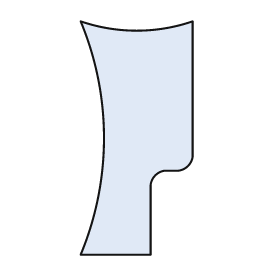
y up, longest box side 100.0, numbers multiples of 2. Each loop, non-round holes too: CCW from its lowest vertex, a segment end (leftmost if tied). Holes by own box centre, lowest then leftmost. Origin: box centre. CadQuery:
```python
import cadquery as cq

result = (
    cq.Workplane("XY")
    .moveTo(-24.0, -50.0)
    .lineTo(6.0, -50.0)
    .lineTo(6.0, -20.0)
    .threePointArc((8.0, -16.0), (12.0, -14.0))
    .lineTo(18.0, -14.0)
    .threePointArc((22.0, -12.0), (24.0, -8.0))
    .lineTo(24.0, 50.0)
    .threePointArc((0.0, 46.0), (-24.0, 50.0))
    .threePointArc((-14.0, 0.0), (-24.0, -50.0))
    .close()
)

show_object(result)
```